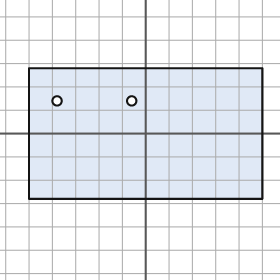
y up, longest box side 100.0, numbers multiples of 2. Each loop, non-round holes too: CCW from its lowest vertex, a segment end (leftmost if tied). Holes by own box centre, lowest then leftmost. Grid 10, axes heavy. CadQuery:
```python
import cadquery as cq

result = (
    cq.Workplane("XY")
    .moveTo(-50.0, -28.0)
    .lineTo(50.0, -28.0)
    .lineTo(50.0, 28.0)
    .lineTo(-50.0, 28.0)
    .close()
    .moveTo(-38.0, 14.0)
    .circle(2.0)
    .moveTo(-6.0, 14.0)
    .circle(2.0)
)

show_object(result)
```